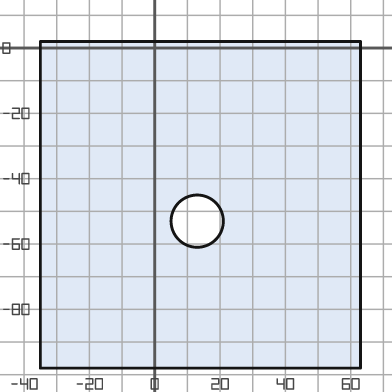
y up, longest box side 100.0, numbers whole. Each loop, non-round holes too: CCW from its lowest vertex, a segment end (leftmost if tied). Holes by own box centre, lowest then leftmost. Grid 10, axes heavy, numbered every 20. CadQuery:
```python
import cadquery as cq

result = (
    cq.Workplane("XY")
    .moveTo(-35.0, -98.0)
    .lineTo(63.0, -98.0)
    .lineTo(63.0, 2.0)
    .lineTo(-35.0, 2.0)
    .close()
    .moveTo(13.0, -53.0)
    .circle(8.0)
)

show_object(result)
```